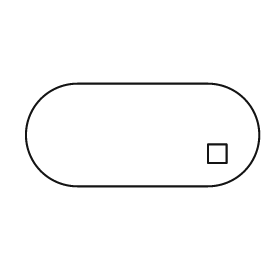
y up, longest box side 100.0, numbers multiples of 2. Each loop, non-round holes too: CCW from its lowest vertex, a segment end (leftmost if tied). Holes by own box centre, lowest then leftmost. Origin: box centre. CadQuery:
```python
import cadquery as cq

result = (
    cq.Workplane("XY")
    .moveTo(-28.0, -22.0)
    .lineTo(28.0, -22.0)
    .threePointArc((50.0, 0.0), (28.0, 22.0))
    .lineTo(-28.0, 22.0)
    .threePointArc((-50.0, 0.0), (-28.0, -22.0))
    .close()
    .moveTo(28.0, -12.0)
    .lineTo(36.0, -12.0)
    .lineTo(36.0, -4.0)
    .lineTo(28.0, -4.0)
    .close()
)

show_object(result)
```